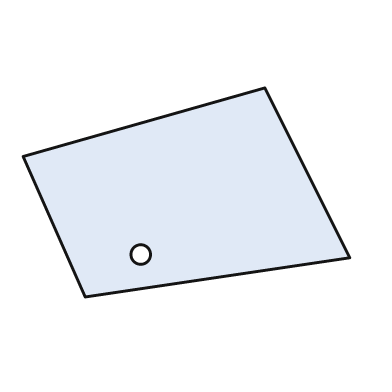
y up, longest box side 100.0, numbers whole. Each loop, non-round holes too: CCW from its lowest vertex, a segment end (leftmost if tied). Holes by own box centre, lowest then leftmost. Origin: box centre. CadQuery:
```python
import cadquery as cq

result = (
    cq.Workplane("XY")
    .moveTo(-31.0, -32.0)
    .lineTo(50.0, -20.0)
    .lineTo(24.0, 32.0)
    .lineTo(-50.0, 11.0)
    .close()
    .moveTo(-14.0, -19.0)
    .circle(3.0)
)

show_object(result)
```